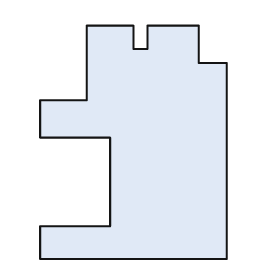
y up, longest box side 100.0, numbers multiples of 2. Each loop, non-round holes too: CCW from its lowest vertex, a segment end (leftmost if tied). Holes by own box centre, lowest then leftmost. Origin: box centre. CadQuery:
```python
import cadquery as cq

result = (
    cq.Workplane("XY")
    .moveTo(-40.0, -50.0)
    .lineTo(40.0, -50.0)
    .lineTo(40.0, 34.0)
    .lineTo(28.0, 34.0)
    .lineTo(28.0, 50.0)
    .lineTo(6.0, 50.0)
    .lineTo(6.0, 40.0)
    .lineTo(0.0, 40.0)
    .lineTo(0.0, 50.0)
    .lineTo(-20.0, 50.0)
    .lineTo(-20.0, 18.0)
    .lineTo(-40.0, 18.0)
    .lineTo(-40.0, 2.0)
    .lineTo(-10.0, 2.0)
    .lineTo(-10.0, -36.0)
    .lineTo(-40.0, -36.0)
    .close()
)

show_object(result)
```